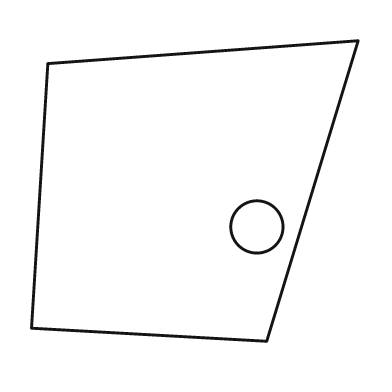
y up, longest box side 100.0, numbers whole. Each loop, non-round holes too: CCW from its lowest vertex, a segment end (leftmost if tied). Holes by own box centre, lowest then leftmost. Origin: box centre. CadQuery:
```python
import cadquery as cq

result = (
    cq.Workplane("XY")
    .moveTo(22.0, -46.0)
    .lineTo(50.0, 46.0)
    .lineTo(-45.0, 39.0)
    .lineTo(-50.0, -42.0)
    .close()
    .moveTo(19.0, -11.0)
    .circle(8.0)
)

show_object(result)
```